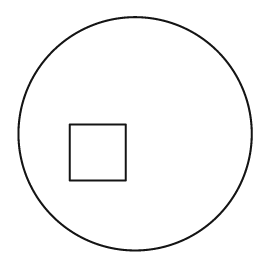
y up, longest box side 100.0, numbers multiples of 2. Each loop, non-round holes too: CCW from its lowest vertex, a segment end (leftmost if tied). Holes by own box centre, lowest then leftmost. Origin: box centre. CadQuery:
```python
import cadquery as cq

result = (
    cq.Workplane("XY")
    .moveTo(0.0, 0.0)
    .circle(50.0)
    .moveTo(-28.0, -20.0)
    .lineTo(-4.0, -20.0)
    .lineTo(-4.0, 4.0)
    .lineTo(-28.0, 4.0)
    .close()
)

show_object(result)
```